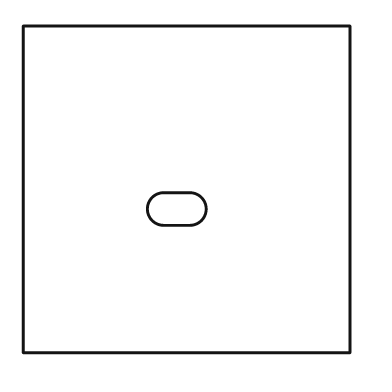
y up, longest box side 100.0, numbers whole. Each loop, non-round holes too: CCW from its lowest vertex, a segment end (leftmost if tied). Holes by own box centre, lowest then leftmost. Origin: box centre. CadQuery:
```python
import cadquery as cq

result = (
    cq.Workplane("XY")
    .moveTo(-50.0, -50.0)
    .lineTo(50.0, -50.0)
    .lineTo(50.0, 50.0)
    .lineTo(-50.0, 50.0)
    .close()
    .moveTo(-7.0, -11.0)
    .lineTo(1.0, -11.0)
    .threePointArc((6.0, -6.0), (1.0, -1.0))
    .lineTo(-7.0, -1.0)
    .threePointArc((-12.0, -6.0), (-7.0, -11.0))
    .close()
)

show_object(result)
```